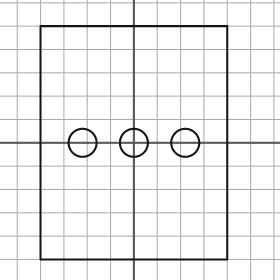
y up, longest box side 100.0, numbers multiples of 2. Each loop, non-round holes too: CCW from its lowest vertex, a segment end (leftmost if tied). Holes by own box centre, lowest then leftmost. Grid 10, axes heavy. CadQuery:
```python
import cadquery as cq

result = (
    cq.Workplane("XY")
    .moveTo(-40.0, -50.0)
    .lineTo(40.0, -50.0)
    .lineTo(40.0, 50.0)
    .lineTo(-40.0, 50.0)
    .close()
    .moveTo(-22.0, 0.0)
    .circle(6.0)
    .moveTo(0.0, 0.0)
    .circle(6.0)
    .moveTo(22.0, 0.0)
    .circle(6.0)
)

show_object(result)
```